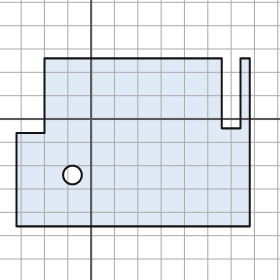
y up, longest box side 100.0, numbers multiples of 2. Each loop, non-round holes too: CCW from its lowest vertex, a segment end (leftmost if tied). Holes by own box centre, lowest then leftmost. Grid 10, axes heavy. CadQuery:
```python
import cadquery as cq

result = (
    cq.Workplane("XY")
    .moveTo(-32.0, -46.0)
    .lineTo(68.0, -46.0)
    .lineTo(68.0, 26.0)
    .lineTo(64.0, 26.0)
    .lineTo(64.0, -4.0)
    .lineTo(56.0, -4.0)
    .lineTo(56.0, 26.0)
    .lineTo(-20.0, 26.0)
    .lineTo(-20.0, -6.0)
    .lineTo(-32.0, -6.0)
    .close()
    .moveTo(-8.0, -24.0)
    .circle(4.0)
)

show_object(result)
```